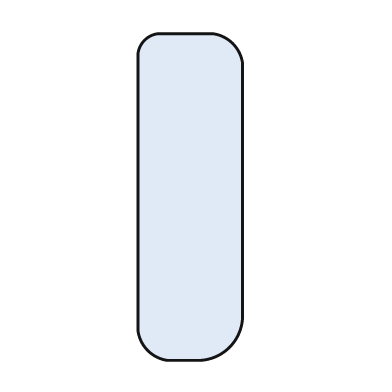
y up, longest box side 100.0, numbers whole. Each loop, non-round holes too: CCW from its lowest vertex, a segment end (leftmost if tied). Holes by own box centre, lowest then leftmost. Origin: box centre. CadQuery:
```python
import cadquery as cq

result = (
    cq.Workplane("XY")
    .moveTo(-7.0, -50.0)
    .lineTo(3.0, -50.0)
    .threePointArc((12.0, -46.0), (16.0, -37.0))
    .lineTo(16.0, 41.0)
    .threePointArc((13.0, 47.0), (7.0, 50.0))
    .lineTo(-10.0, 50.0)
    .threePointArc((-14.0, 48.0), (-16.0, 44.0))
    .lineTo(-16.0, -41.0)
    .threePointArc((-13.0, -47.0), (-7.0, -50.0))
    .close()
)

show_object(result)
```